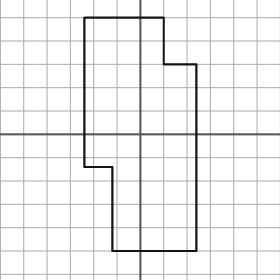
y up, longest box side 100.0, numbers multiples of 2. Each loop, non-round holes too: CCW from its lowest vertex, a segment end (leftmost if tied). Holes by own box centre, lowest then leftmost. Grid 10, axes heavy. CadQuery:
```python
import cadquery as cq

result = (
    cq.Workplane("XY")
    .moveTo(-12.0, -50.0)
    .lineTo(24.0, -50.0)
    .lineTo(24.0, 30.0)
    .lineTo(10.0, 30.0)
    .lineTo(10.0, 50.0)
    .lineTo(-24.0, 50.0)
    .lineTo(-24.0, -14.0)
    .lineTo(-12.0, -14.0)
    .close()
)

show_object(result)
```